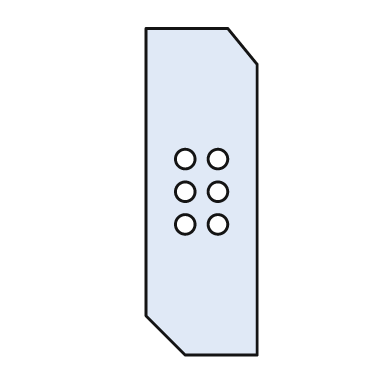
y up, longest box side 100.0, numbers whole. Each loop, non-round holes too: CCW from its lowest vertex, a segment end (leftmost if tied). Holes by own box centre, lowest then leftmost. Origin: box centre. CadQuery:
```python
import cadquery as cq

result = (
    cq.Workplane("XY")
    .moveTo(-5.0, -50.0)
    .lineTo(17.0, -50.0)
    .lineTo(17.0, 39.0)
    .lineTo(8.0, 50.0)
    .lineTo(-17.0, 50.0)
    .lineTo(-17.0, -38.0)
    .close()
    .moveTo(-5.0, -10.0)
    .circle(3.0)
    .moveTo(5.0, -10.0)
    .circle(3.0)
    .moveTo(-5.0, 0.0)
    .circle(3.0)
    .moveTo(5.0, 0.0)
    .circle(3.0)
    .moveTo(-5.0, 10.0)
    .circle(3.0)
    .moveTo(5.0, 10.0)
    .circle(3.0)
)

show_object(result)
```